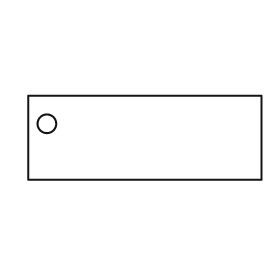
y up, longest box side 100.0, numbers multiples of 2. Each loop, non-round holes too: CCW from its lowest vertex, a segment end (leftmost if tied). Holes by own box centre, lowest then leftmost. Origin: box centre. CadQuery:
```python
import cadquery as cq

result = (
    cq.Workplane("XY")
    .moveTo(-50.0, -18.0)
    .lineTo(50.0, -18.0)
    .lineTo(50.0, 18.0)
    .lineTo(-50.0, 18.0)
    .close()
    .moveTo(-42.0, 6.0)
    .circle(4.0)
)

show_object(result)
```